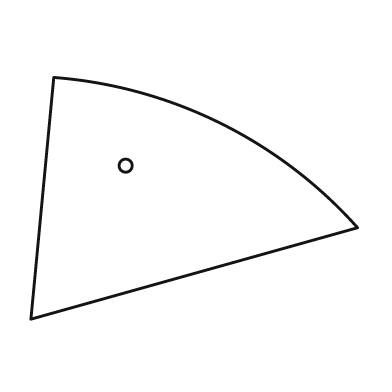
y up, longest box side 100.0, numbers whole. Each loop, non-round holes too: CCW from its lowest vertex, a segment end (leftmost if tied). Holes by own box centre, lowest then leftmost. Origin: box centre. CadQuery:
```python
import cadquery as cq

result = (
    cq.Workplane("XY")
    .moveTo(-50.0, -37.0)
    .lineTo(50.0, -9.0)
    .threePointArc((8.0, 23.0), (-43.0, 37.0))
    .close()
    .moveTo(-21.0, 10.0)
    .circle(2.0)
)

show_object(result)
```